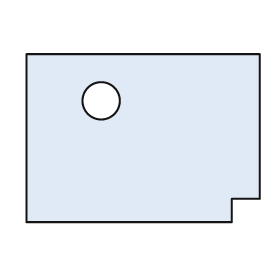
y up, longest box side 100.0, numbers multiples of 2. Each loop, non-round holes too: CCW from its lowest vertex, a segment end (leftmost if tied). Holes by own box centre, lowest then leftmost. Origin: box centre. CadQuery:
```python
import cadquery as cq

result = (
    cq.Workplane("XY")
    .moveTo(-50.0, -36.0)
    .lineTo(38.0, -36.0)
    .lineTo(38.0, -26.0)
    .lineTo(50.0, -26.0)
    .lineTo(50.0, 36.0)
    .lineTo(-50.0, 36.0)
    .close()
    .moveTo(-18.0, 16.0)
    .circle(8.0)
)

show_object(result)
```